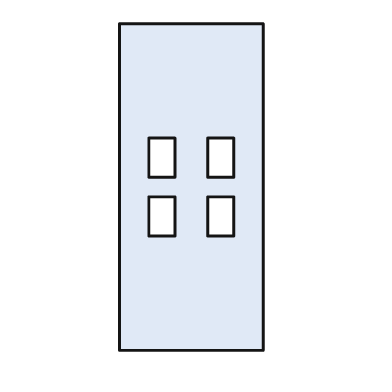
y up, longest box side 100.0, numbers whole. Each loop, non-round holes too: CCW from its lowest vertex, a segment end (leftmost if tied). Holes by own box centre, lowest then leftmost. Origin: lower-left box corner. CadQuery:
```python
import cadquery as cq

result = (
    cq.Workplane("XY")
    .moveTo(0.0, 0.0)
    .lineTo(44.0, 0.0)
    .lineTo(44.0, 100.0)
    .lineTo(0.0, 100.0)
    .close()
    .moveTo(9.0, 35.0)
    .lineTo(17.0, 35.0)
    .lineTo(17.0, 47.0)
    .lineTo(9.0, 47.0)
    .close()
    .moveTo(27.0, 35.0)
    .lineTo(35.0, 35.0)
    .lineTo(35.0, 47.0)
    .lineTo(27.0, 47.0)
    .close()
    .moveTo(9.0, 53.0)
    .lineTo(17.0, 53.0)
    .lineTo(17.0, 65.0)
    .lineTo(9.0, 65.0)
    .close()
    .moveTo(27.0, 53.0)
    .lineTo(35.0, 53.0)
    .lineTo(35.0, 65.0)
    .lineTo(27.0, 65.0)
    .close()
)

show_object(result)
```